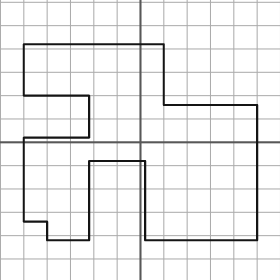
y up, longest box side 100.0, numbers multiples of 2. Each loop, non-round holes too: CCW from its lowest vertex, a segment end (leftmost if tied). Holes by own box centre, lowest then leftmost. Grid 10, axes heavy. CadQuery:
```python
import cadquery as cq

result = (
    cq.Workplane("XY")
    .moveTo(-40.0, -42.0)
    .lineTo(-22.0, -42.0)
    .lineTo(-22.0, -8.0)
    .lineTo(2.0, -8.0)
    .lineTo(2.0, -42.0)
    .lineTo(50.0, -42.0)
    .lineTo(50.0, 16.0)
    .lineTo(10.0, 16.0)
    .lineTo(10.0, 42.0)
    .lineTo(-50.0, 42.0)
    .lineTo(-50.0, 20.0)
    .lineTo(-22.0, 20.0)
    .lineTo(-22.0, 2.0)
    .lineTo(-50.0, 2.0)
    .lineTo(-50.0, -34.0)
    .lineTo(-40.0, -34.0)
    .close()
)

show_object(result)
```